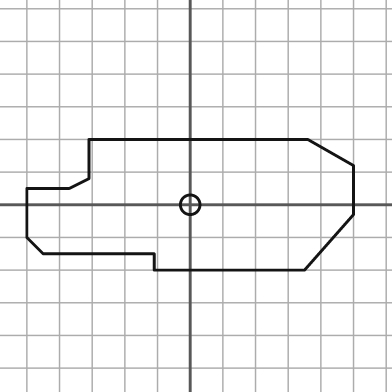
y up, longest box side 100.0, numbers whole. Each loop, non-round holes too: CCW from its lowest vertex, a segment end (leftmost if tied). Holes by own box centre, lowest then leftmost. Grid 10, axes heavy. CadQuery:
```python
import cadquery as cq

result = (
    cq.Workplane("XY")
    .moveTo(-11.0, -20.0)
    .lineTo(35.0, -20.0)
    .lineTo(50.0, -3.0)
    .lineTo(50.0, 12.0)
    .lineTo(36.0, 20.0)
    .lineTo(-31.0, 20.0)
    .lineTo(-31.0, 8.0)
    .lineTo(-37.0, 5.0)
    .lineTo(-50.0, 5.0)
    .lineTo(-50.0, -10.0)
    .lineTo(-45.0, -15.0)
    .lineTo(-11.0, -15.0)
    .close()
    .moveTo(0.0, 0.0)
    .circle(3.0)
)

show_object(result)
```